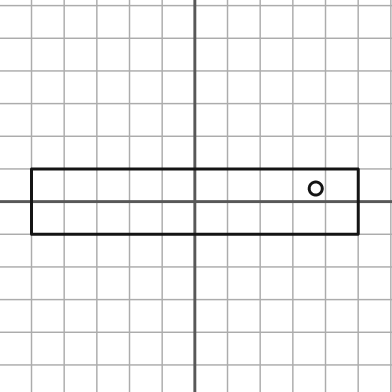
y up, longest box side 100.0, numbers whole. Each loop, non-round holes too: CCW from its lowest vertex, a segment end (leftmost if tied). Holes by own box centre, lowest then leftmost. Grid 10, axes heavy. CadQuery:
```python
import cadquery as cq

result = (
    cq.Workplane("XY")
    .moveTo(-50.0, -10.0)
    .lineTo(50.0, -10.0)
    .lineTo(50.0, 10.0)
    .lineTo(-50.0, 10.0)
    .close()
    .moveTo(37.0, 4.0)
    .circle(2.0)
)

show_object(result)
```